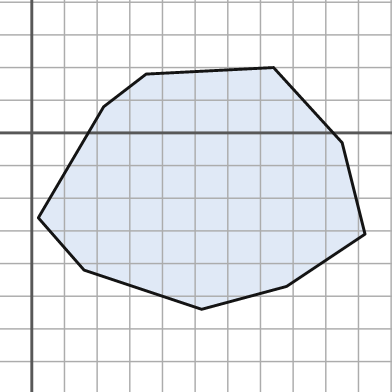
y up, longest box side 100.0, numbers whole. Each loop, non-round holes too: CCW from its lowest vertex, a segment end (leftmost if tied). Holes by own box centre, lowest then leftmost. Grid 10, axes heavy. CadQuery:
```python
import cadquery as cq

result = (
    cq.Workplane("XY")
    .moveTo(52.0, -54.0)
    .lineTo(78.0, -47.0)
    .lineTo(102.0, -31.0)
    .lineTo(95.0, -3.0)
    .lineTo(74.0, 20.0)
    .lineTo(35.0, 18.0)
    .lineTo(22.0, 8.0)
    .lineTo(2.0, -26.0)
    .lineTo(16.0, -42.0)
    .close()
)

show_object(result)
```